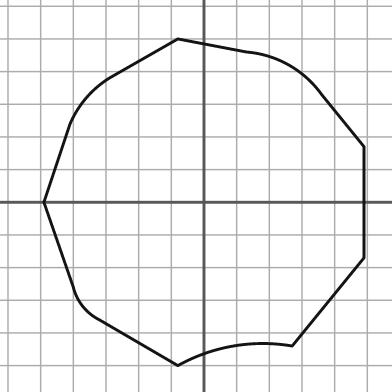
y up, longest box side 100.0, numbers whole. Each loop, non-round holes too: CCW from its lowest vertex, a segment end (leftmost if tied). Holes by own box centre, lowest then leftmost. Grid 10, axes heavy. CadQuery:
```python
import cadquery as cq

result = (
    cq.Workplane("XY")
    .moveTo(-8.0, -50.0)
    .threePointArc((9.0, -44.0), (27.0, -44.0))
    .lineTo(49.0, -17.0)
    .lineTo(49.0, 17.0)
    .lineTo(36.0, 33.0)
    .threePointArc((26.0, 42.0), (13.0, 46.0))
    .lineTo(-8.0, 50.0)
    .lineTo(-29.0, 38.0)
    .threePointArc((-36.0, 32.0), (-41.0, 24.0))
    .lineTo(-49.0, 0.0)
    .lineTo(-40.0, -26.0)
    .threePointArc((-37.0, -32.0), (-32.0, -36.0))
    .close()
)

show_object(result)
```